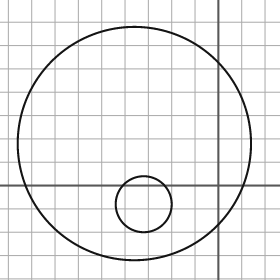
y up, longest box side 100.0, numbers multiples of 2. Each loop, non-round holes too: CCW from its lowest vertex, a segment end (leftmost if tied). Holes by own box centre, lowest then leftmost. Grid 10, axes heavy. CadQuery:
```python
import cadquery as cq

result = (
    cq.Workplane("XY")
    .moveTo(-36.0, 18.0)
    .circle(50.0)
    .moveTo(-32.0, -8.0)
    .circle(12.0)
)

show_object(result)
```